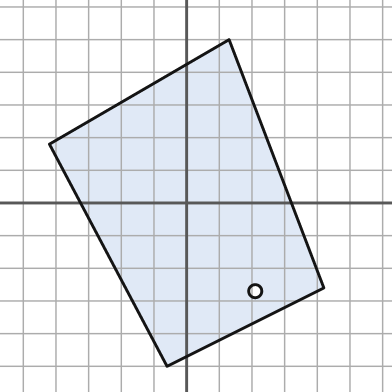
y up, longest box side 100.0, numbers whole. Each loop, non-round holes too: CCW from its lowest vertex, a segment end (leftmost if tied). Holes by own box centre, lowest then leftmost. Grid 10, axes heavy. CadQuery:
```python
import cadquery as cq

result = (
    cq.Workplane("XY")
    .moveTo(-6.0, -50.0)
    .lineTo(42.0, -26.0)
    .lineTo(13.0, 50.0)
    .lineTo(-42.0, 18.0)
    .close()
    .moveTo(21.0, -27.0)
    .circle(2.0)
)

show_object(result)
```